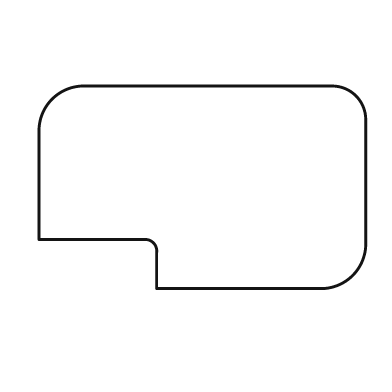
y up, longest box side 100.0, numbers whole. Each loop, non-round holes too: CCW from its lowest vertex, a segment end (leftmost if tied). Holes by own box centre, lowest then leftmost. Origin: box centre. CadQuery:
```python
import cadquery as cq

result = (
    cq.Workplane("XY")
    .moveTo(-14.0, -31.0)
    .lineTo(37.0, -31.0)
    .threePointArc((46.0, -27.0), (50.0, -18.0))
    .lineTo(50.0, 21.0)
    .threePointArc((47.0, 28.0), (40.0, 31.0))
    .lineTo(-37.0, 31.0)
    .threePointArc((-46.0, 27.0), (-50.0, 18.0))
    .lineTo(-50.0, -16.0)
    .lineTo(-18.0, -16.0)
    .threePointArc((-15.0, -17.0), (-14.0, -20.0))
    .close()
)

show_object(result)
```